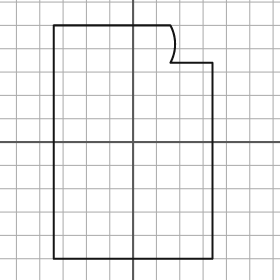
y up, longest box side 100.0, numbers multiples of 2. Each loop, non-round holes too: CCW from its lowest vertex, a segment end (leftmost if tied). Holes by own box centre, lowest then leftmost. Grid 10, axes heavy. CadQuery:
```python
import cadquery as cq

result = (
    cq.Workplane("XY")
    .moveTo(-34.0, -50.0)
    .lineTo(34.0, -50.0)
    .lineTo(34.0, 34.0)
    .lineTo(16.0, 34.0)
    .threePointArc((18.0, 42.0), (16.0, 50.0))
    .lineTo(-34.0, 50.0)
    .close()
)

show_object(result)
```